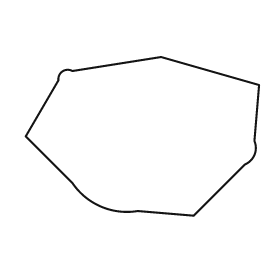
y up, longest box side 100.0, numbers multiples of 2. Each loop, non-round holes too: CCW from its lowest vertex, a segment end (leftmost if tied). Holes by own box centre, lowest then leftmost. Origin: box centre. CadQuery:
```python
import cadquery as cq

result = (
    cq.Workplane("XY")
    .moveTo(22.0, -34.0)
    .lineTo(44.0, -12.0)
    .threePointArc((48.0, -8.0), (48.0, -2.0))
    .lineTo(50.0, 22.0)
    .lineTo(8.0, 34.0)
    .lineTo(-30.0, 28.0)
    .threePointArc((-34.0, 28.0), (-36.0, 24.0))
    .lineTo(-50.0, 0.0)
    .lineTo(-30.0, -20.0)
    .threePointArc((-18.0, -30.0), (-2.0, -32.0))
    .close()
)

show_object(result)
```